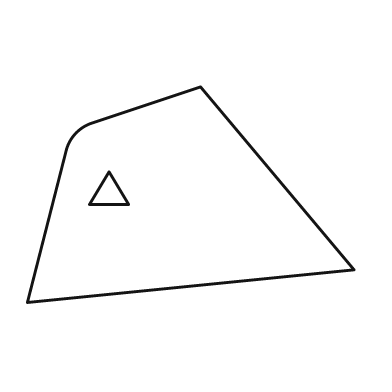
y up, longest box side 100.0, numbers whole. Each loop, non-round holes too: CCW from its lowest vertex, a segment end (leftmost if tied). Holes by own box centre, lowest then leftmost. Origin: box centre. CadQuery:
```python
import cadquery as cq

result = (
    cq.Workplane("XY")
    .moveTo(-50.0, -33.0)
    .lineTo(50.0, -23.0)
    .lineTo(3.0, 33.0)
    .lineTo(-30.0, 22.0)
    .threePointArc((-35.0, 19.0), (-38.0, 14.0))
    .close()
    .moveTo(-31.0, -3.0)
    .lineTo(-19.0, -3.0)
    .lineTo(-25.0, 7.0)
    .close()
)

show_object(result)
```